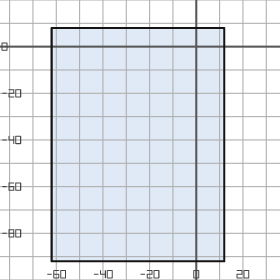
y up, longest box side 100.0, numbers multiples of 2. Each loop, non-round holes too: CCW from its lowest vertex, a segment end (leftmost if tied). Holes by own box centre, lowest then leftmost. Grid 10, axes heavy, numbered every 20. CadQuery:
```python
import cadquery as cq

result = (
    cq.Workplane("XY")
    .moveTo(-62.0, -92.0)
    .lineTo(12.0, -92.0)
    .lineTo(12.0, 8.0)
    .lineTo(-62.0, 8.0)
    .close()
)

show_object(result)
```